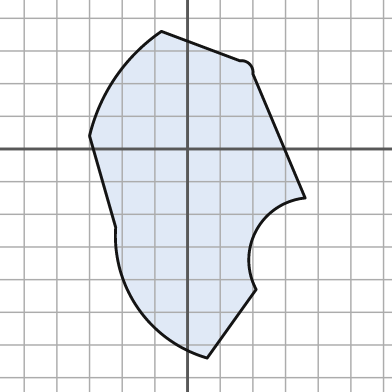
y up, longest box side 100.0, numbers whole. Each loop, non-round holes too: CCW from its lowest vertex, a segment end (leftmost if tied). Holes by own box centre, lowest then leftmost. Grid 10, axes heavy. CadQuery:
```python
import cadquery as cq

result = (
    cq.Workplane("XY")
    .moveTo(6.0, -64.0)
    .lineTo(21.0, -43.0)
    .threePointArc((21.0, -25.0), (36.0, -15.0))
    .lineTo(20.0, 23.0)
    .threePointArc((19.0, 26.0), (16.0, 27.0))
    .lineTo(-8.0, 36.0)
    .threePointArc((-22.0, 22.0), (-30.0, 4.0))
    .lineTo(-22.0, -24.0)
    .threePointArc((-15.0, -49.0), (6.0, -64.0))
    .close()
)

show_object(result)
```